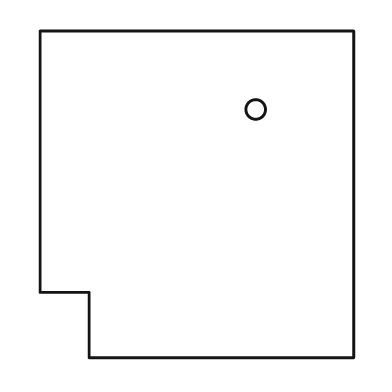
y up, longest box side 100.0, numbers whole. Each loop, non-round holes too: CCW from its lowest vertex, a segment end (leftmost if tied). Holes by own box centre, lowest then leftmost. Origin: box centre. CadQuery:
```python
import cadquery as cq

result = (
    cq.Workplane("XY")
    .moveTo(-33.0, -50.0)
    .lineTo(48.0, -50.0)
    .lineTo(48.0, 50.0)
    .lineTo(-48.0, 50.0)
    .lineTo(-48.0, -30.0)
    .lineTo(-33.0, -30.0)
    .close()
    .moveTo(18.0, 26.0)
    .circle(3.0)
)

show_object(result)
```